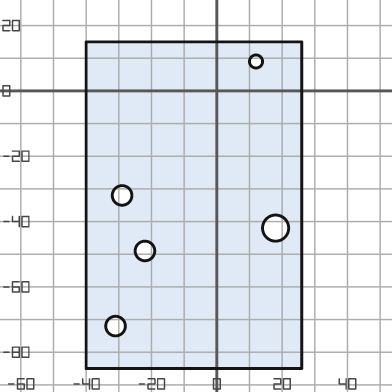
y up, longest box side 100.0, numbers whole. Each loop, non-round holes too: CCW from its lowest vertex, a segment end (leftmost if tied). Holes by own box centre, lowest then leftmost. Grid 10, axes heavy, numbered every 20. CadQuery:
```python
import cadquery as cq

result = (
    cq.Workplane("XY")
    .moveTo(-40.0, -85.0)
    .lineTo(26.0, -85.0)
    .lineTo(26.0, 15.0)
    .lineTo(-40.0, 15.0)
    .close()
    .moveTo(-31.0, -72.0)
    .circle(3.0)
    .moveTo(-22.0, -49.0)
    .circle(3.0)
    .moveTo(18.0, -42.0)
    .circle(4.0)
    .moveTo(-29.0, -32.0)
    .circle(3.0)
    .moveTo(12.0, 9.0)
    .circle(2.0)
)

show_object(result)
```